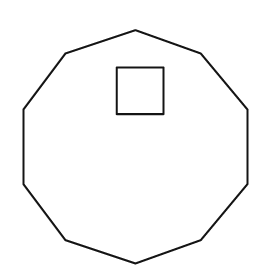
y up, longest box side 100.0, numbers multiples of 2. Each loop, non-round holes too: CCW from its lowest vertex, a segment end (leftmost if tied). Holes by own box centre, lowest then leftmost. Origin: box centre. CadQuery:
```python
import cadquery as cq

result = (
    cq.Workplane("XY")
    .moveTo(0.0, -50.0)
    .lineTo(28.0, -40.0)
    .lineTo(48.0, -16.0)
    .lineTo(48.0, 16.0)
    .lineTo(28.0, 40.0)
    .lineTo(0.0, 50.0)
    .lineTo(-30.0, 40.0)
    .lineTo(-48.0, 16.0)
    .lineTo(-48.0, -16.0)
    .lineTo(-30.0, -40.0)
    .close()
    .moveTo(-8.0, 14.0)
    .lineTo(12.0, 14.0)
    .lineTo(12.0, 34.0)
    .lineTo(-8.0, 34.0)
    .close()
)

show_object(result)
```